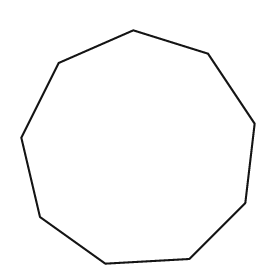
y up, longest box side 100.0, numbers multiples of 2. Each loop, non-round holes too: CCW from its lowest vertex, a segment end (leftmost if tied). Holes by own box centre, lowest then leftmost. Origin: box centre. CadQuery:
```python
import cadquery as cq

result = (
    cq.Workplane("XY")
    .moveTo(-14.0, -50.0)
    .lineTo(22.0, -48.0)
    .lineTo(46.0, -24.0)
    .lineTo(50.0, 10.0)
    .lineTo(30.0, 40.0)
    .lineTo(-2.0, 50.0)
    .lineTo(-34.0, 36.0)
    .lineTo(-50.0, 4.0)
    .lineTo(-42.0, -30.0)
    .close()
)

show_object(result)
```